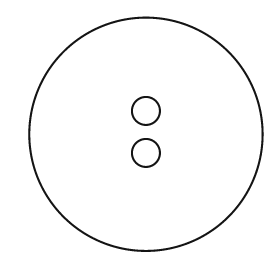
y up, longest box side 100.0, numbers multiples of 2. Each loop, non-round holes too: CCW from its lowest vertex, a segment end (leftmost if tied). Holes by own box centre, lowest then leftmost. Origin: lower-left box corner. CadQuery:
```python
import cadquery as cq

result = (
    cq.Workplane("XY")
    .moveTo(50.0, 50.0)
    .circle(50.0)
    .moveTo(50.0, 42.0)
    .circle(6.0)
    .moveTo(50.0, 60.0)
    .circle(6.0)
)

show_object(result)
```